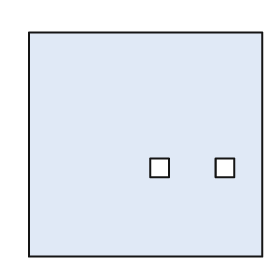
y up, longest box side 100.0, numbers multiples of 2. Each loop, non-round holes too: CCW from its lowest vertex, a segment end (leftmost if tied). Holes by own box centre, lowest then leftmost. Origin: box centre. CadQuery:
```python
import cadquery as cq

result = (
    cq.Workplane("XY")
    .moveTo(-50.0, -48.0)
    .lineTo(50.0, -48.0)
    .lineTo(50.0, 48.0)
    .lineTo(-50.0, 48.0)
    .close()
    .moveTo(2.0, -14.0)
    .lineTo(10.0, -14.0)
    .lineTo(10.0, -6.0)
    .lineTo(2.0, -6.0)
    .close()
    .moveTo(30.0, -14.0)
    .lineTo(38.0, -14.0)
    .lineTo(38.0, -6.0)
    .lineTo(30.0, -6.0)
    .close()
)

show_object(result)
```